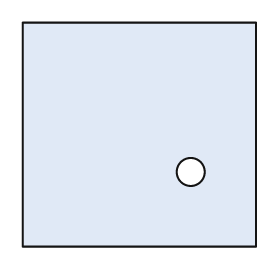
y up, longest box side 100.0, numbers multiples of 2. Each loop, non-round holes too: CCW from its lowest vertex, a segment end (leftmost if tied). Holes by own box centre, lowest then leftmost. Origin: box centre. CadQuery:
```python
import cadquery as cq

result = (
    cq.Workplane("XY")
    .moveTo(-50.0, -48.0)
    .lineTo(50.0, -48.0)
    .lineTo(50.0, 48.0)
    .lineTo(-50.0, 48.0)
    .close()
    .moveTo(22.0, -16.0)
    .circle(6.0)
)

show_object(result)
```